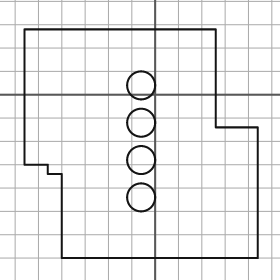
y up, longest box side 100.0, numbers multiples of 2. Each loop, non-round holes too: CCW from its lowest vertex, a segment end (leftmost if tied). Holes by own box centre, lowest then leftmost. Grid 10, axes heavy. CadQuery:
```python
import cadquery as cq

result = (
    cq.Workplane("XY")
    .moveTo(-40.0, -70.0)
    .lineTo(44.0, -70.0)
    .lineTo(44.0, -14.0)
    .lineTo(26.0, -14.0)
    .lineTo(26.0, 28.0)
    .lineTo(-56.0, 28.0)
    .lineTo(-56.0, -30.0)
    .lineTo(-46.0, -30.0)
    .lineTo(-46.0, -34.0)
    .lineTo(-40.0, -34.0)
    .close()
    .moveTo(-6.0, -44.0)
    .circle(6.0)
    .moveTo(-6.0, -28.0)
    .circle(6.0)
    .moveTo(-6.0, -12.0)
    .circle(6.0)
    .moveTo(-6.0, 4.0)
    .circle(6.0)
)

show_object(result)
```